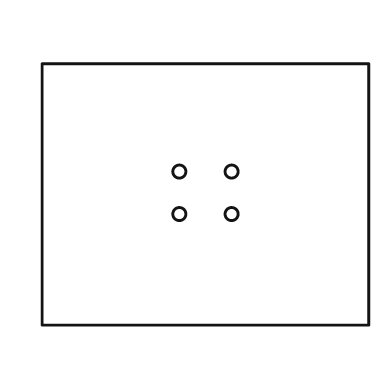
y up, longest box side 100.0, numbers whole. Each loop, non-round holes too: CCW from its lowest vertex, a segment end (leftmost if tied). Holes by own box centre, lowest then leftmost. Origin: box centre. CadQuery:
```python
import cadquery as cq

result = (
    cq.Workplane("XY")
    .moveTo(-50.0, -40.0)
    .lineTo(50.0, -40.0)
    .lineTo(50.0, 40.0)
    .lineTo(-50.0, 40.0)
    .close()
    .moveTo(-8.0, -6.0)
    .circle(2.0)
    .moveTo(8.0, -6.0)
    .circle(2.0)
    .moveTo(-8.0, 7.0)
    .circle(2.0)
    .moveTo(8.0, 7.0)
    .circle(2.0)
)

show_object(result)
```